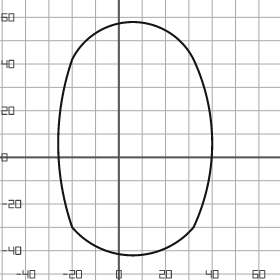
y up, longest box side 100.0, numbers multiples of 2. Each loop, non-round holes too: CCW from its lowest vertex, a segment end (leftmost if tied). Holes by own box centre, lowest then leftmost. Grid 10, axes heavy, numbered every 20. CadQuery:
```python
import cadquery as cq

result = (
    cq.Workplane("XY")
    .moveTo(-20.0, -30.0)
    .threePointArc((6.0, -42.0), (32.0, -30.0))
    .threePointArc((40.0, 6.0), (32.0, 42.0))
    .threePointArc((6.0, 58.0), (-20.0, 42.0))
    .threePointArc((-26.0, 6.0), (-20.0, -30.0))
    .close()
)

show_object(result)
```